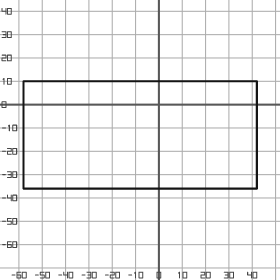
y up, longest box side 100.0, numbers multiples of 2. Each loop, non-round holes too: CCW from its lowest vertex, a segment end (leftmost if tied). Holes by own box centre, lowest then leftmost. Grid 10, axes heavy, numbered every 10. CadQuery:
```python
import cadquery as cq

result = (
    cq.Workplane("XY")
    .moveTo(-58.0, -36.0)
    .lineTo(42.0, -36.0)
    .lineTo(42.0, 10.0)
    .lineTo(-58.0, 10.0)
    .close()
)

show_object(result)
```